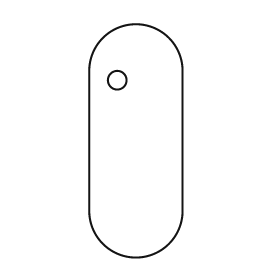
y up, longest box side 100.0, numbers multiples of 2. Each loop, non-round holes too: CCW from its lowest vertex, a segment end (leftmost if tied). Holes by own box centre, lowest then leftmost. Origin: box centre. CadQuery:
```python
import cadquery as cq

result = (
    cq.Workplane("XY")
    .moveTo(-20.0, -30.0)
    .threePointArc((0.0, -50.0), (20.0, -30.0))
    .lineTo(20.0, 30.0)
    .threePointArc((0.0, 50.0), (-20.0, 30.0))
    .close()
    .moveTo(-8.0, 26.0)
    .circle(4.0)
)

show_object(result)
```